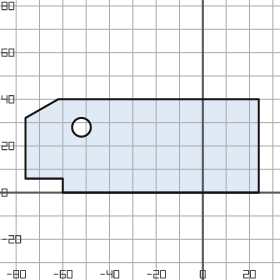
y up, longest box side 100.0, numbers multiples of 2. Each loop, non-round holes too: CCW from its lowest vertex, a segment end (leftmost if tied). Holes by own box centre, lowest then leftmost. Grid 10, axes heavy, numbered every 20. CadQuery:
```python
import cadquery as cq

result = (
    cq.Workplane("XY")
    .moveTo(-60.0, 0.0)
    .lineTo(24.0, 0.0)
    .lineTo(24.0, 40.0)
    .lineTo(-62.0, 40.0)
    .lineTo(-76.0, 32.0)
    .lineTo(-76.0, 6.0)
    .lineTo(-60.0, 6.0)
    .close()
    .moveTo(-52.0, 28.0)
    .circle(4.0)
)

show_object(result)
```